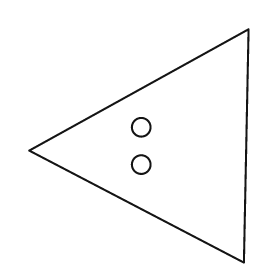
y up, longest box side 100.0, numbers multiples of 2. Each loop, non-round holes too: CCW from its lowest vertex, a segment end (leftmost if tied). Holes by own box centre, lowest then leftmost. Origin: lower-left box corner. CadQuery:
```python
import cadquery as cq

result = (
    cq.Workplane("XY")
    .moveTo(92.0, 0.0)
    .lineTo(94.0, 100.0)
    .lineTo(0.0, 48.0)
    .close()
    .moveTo(48.0, 42.0)
    .circle(4.0)
    .moveTo(48.0, 58.0)
    .circle(4.0)
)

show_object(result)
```